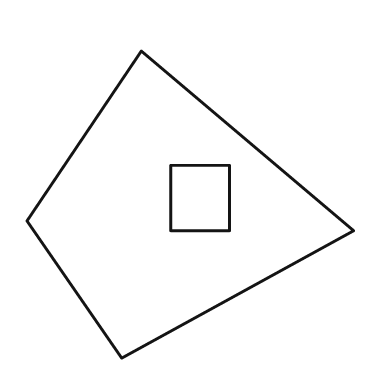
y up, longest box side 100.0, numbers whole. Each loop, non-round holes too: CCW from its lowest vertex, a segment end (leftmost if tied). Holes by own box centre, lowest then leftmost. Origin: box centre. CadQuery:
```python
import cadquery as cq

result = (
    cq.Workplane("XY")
    .moveTo(-21.0, -47.0)
    .lineTo(50.0, -8.0)
    .lineTo(-15.0, 47.0)
    .lineTo(-50.0, -5.0)
    .close()
    .moveTo(-6.0, -8.0)
    .lineTo(12.0, -8.0)
    .lineTo(12.0, 12.0)
    .lineTo(-6.0, 12.0)
    .close()
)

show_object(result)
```